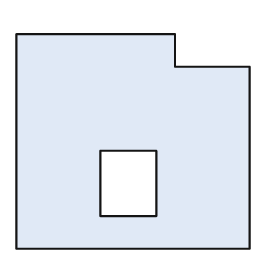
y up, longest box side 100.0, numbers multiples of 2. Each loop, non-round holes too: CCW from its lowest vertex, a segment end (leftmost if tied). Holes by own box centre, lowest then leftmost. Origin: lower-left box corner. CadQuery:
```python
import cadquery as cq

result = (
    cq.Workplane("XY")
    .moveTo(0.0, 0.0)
    .lineTo(100.0, 0.0)
    .lineTo(100.0, 78.0)
    .lineTo(68.0, 78.0)
    .lineTo(68.0, 92.0)
    .lineTo(0.0, 92.0)
    .close()
    .moveTo(36.0, 14.0)
    .lineTo(60.0, 14.0)
    .lineTo(60.0, 42.0)
    .lineTo(36.0, 42.0)
    .close()
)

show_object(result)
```